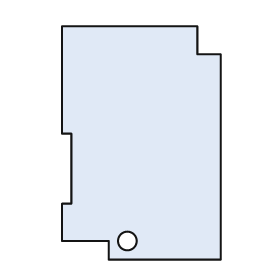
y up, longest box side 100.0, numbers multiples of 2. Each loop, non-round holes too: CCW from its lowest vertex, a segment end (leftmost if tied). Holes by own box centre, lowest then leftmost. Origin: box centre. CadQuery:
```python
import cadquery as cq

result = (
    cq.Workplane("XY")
    .moveTo(-14.0, -50.0)
    .lineTo(34.0, -50.0)
    .lineTo(34.0, 38.0)
    .lineTo(24.0, 38.0)
    .lineTo(24.0, 50.0)
    .lineTo(-34.0, 50.0)
    .lineTo(-34.0, 4.0)
    .lineTo(-30.0, 4.0)
    .lineTo(-30.0, -26.0)
    .lineTo(-34.0, -26.0)
    .lineTo(-34.0, -42.0)
    .lineTo(-14.0, -42.0)
    .close()
    .moveTo(-6.0, -42.0)
    .circle(4.0)
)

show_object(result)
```